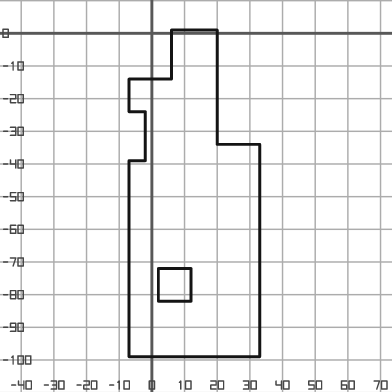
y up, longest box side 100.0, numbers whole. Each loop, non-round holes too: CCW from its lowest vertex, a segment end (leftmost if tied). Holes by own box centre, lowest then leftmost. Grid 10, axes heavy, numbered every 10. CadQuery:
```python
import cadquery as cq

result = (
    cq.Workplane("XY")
    .moveTo(-7.0, -99.0)
    .lineTo(33.0, -99.0)
    .lineTo(33.0, -34.0)
    .lineTo(20.0, -34.0)
    .lineTo(20.0, 1.0)
    .lineTo(6.0, 1.0)
    .lineTo(6.0, -14.0)
    .lineTo(-7.0, -14.0)
    .lineTo(-7.0, -24.0)
    .lineTo(-2.0, -24.0)
    .lineTo(-2.0, -39.0)
    .lineTo(-7.0, -39.0)
    .close()
    .moveTo(2.0, -82.0)
    .lineTo(12.0, -82.0)
    .lineTo(12.0, -72.0)
    .lineTo(2.0, -72.0)
    .close()
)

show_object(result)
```